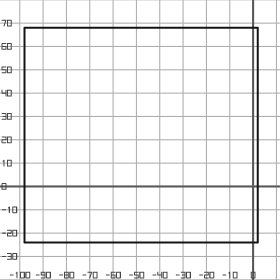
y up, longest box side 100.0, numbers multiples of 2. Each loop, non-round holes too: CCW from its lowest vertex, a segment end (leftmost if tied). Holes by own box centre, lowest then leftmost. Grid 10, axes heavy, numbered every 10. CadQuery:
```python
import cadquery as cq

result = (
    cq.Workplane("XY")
    .moveTo(-98.0, -24.0)
    .lineTo(2.0, -24.0)
    .lineTo(2.0, 68.0)
    .lineTo(-98.0, 68.0)
    .close()
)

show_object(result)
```